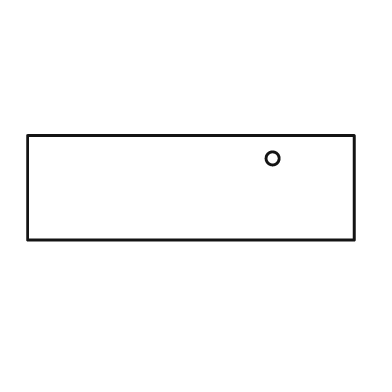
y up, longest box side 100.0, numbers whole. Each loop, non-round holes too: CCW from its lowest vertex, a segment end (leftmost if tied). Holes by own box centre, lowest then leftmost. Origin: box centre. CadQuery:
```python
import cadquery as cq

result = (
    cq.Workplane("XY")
    .moveTo(-50.0, -16.0)
    .lineTo(50.0, -16.0)
    .lineTo(50.0, 16.0)
    .lineTo(-50.0, 16.0)
    .close()
    .moveTo(25.0, 9.0)
    .circle(2.0)
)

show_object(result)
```